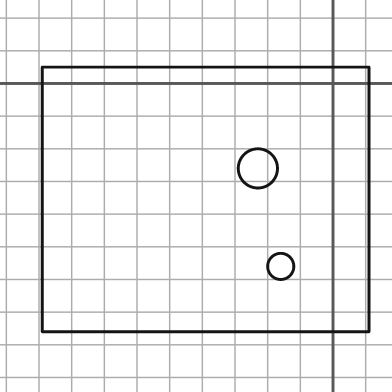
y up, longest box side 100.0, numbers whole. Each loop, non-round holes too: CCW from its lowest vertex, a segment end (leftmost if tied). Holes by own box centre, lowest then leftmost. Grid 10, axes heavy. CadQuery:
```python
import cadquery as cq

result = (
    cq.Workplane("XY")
    .moveTo(-89.0, -76.0)
    .lineTo(11.0, -76.0)
    .lineTo(11.0, 5.0)
    .lineTo(-89.0, 5.0)
    .close()
    .moveTo(-16.0, -56.0)
    .circle(4.0)
    .moveTo(-23.0, -26.0)
    .circle(6.0)
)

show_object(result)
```